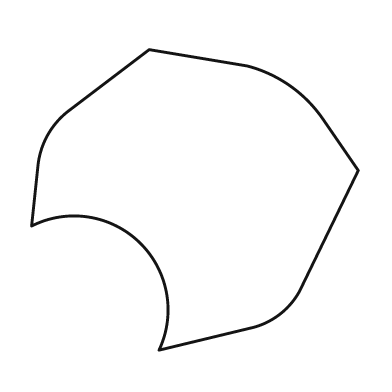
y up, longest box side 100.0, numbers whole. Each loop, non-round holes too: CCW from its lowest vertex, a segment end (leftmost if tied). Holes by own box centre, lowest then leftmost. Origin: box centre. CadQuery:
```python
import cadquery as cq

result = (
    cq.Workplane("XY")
    .moveTo(-11.0, -46.0)
    .lineTo(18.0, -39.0)
    .threePointArc((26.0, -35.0), (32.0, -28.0))
    .lineTo(50.0, 9.0)
    .lineTo(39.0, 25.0)
    .threePointArc((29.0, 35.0), (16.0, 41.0))
    .lineTo(-14.0, 46.0)
    .lineTo(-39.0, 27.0)
    .threePointArc((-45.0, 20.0), (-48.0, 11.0))
    .lineTo(-50.0, -8.0)
    .threePointArc((-17.0, -13.0), (-11.0, -46.0))
    .close()
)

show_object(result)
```